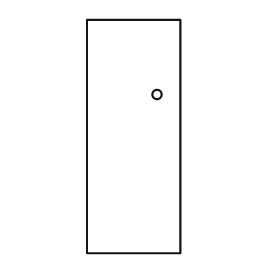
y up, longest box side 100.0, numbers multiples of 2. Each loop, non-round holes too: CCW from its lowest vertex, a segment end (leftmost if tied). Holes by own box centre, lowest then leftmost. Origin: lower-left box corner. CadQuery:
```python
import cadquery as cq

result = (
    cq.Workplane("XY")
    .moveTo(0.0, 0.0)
    .lineTo(40.0, 0.0)
    .lineTo(40.0, 100.0)
    .lineTo(0.0, 100.0)
    .close()
    .moveTo(30.0, 68.0)
    .circle(2.0)
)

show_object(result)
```